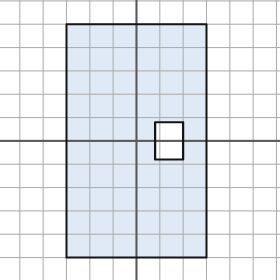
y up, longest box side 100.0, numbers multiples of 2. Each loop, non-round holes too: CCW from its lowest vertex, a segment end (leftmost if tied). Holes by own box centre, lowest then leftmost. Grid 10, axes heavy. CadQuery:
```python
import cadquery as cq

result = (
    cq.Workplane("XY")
    .moveTo(-30.0, -50.0)
    .lineTo(30.0, -50.0)
    .lineTo(30.0, 50.0)
    .lineTo(-30.0, 50.0)
    .close()
    .moveTo(8.0, -8.0)
    .lineTo(20.0, -8.0)
    .lineTo(20.0, 8.0)
    .lineTo(8.0, 8.0)
    .close()
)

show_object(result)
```